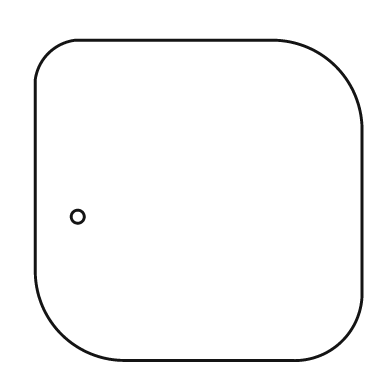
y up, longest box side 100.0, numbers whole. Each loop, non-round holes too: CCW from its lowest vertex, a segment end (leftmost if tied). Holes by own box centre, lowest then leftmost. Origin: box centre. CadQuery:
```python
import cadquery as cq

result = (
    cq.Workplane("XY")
    .moveTo(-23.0, -49.0)
    .lineTo(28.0, -49.0)
    .threePointArc((44.0, -43.0), (50.0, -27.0))
    .lineTo(50.0, 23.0)
    .threePointArc((42.0, 41.0), (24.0, 49.0))
    .lineTo(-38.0, 49.0)
    .threePointArc((-46.0, 45.0), (-50.0, 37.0))
    .lineTo(-50.0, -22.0)
    .threePointArc((-42.0, -41.0), (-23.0, -49.0))
    .close()
    .moveTo(-37.0, -5.0)
    .circle(2.0)
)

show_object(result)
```